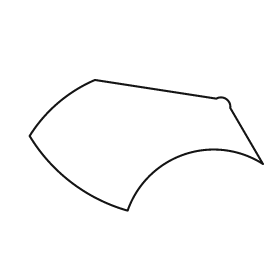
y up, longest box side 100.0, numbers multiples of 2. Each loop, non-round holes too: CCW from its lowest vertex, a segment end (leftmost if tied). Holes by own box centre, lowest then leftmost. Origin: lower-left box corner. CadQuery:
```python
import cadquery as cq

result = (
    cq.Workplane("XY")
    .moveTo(42.0, 0.0)
    .threePointArc((66.0, 24.0), (100.0, 20.0))
    .lineTo(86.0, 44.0)
    .threePointArc((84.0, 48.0), (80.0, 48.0))
    .lineTo(28.0, 56.0)
    .threePointArc((12.0, 46.0), (0.0, 32.0))
    .threePointArc((18.0, 12.0), (42.0, 0.0))
    .close()
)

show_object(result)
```